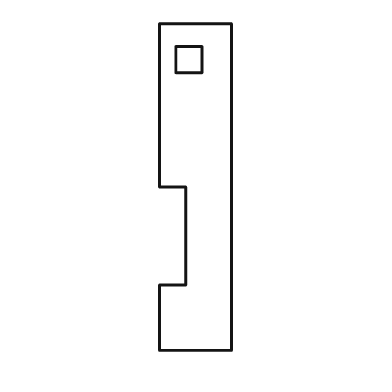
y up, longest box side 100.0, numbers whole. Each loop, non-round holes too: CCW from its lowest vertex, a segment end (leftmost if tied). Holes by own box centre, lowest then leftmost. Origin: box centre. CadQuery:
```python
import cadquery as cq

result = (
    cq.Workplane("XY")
    .moveTo(-11.0, -50.0)
    .lineTo(11.0, -50.0)
    .lineTo(11.0, 50.0)
    .lineTo(-11.0, 50.0)
    .lineTo(-11.0, 0.0)
    .lineTo(-3.0, 0.0)
    .lineTo(-3.0, -30.0)
    .lineTo(-11.0, -30.0)
    .close()
    .moveTo(-6.0, 35.0)
    .lineTo(2.0, 35.0)
    .lineTo(2.0, 43.0)
    .lineTo(-6.0, 43.0)
    .close()
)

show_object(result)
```